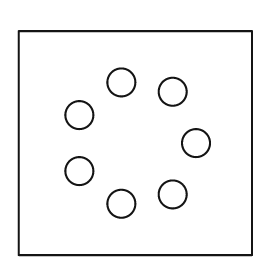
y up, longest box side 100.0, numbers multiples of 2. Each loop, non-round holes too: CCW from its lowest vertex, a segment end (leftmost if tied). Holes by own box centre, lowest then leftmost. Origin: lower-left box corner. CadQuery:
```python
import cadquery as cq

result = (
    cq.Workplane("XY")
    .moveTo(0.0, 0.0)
    .lineTo(100.0, 0.0)
    .lineTo(100.0, 96.0)
    .lineTo(0.0, 96.0)
    .close()
    .moveTo(44.0, 22.0)
    .circle(6.0)
    .moveTo(66.0, 26.0)
    .circle(6.0)
    .moveTo(26.0, 36.0)
    .circle(6.0)
    .moveTo(76.0, 48.0)
    .circle(6.0)
    .moveTo(26.0, 60.0)
    .circle(6.0)
    .moveTo(66.0, 70.0)
    .circle(6.0)
    .moveTo(44.0, 74.0)
    .circle(6.0)
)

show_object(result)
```